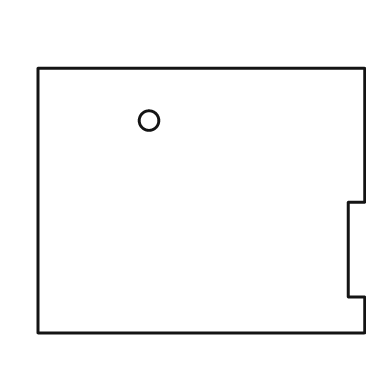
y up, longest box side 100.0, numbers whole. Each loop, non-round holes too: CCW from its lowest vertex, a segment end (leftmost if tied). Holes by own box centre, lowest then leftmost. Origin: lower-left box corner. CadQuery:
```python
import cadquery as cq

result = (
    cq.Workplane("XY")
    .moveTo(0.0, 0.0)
    .lineTo(100.0, 0.0)
    .lineTo(100.0, 11.0)
    .lineTo(95.0, 11.0)
    .lineTo(95.0, 40.0)
    .lineTo(100.0, 40.0)
    .lineTo(100.0, 81.0)
    .lineTo(0.0, 81.0)
    .close()
    .moveTo(34.0, 65.0)
    .circle(3.0)
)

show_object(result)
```